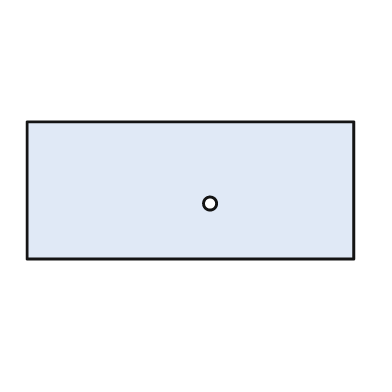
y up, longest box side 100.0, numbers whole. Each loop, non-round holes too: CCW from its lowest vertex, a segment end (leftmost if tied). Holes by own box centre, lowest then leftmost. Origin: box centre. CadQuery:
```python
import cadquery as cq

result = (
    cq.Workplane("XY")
    .moveTo(-50.0, -21.0)
    .lineTo(50.0, -21.0)
    .lineTo(50.0, 21.0)
    .lineTo(-50.0, 21.0)
    .close()
    .moveTo(6.0, -4.0)
    .circle(2.0)
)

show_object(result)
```